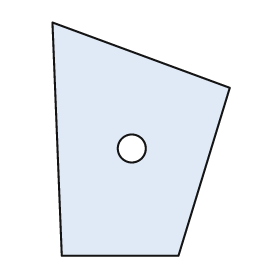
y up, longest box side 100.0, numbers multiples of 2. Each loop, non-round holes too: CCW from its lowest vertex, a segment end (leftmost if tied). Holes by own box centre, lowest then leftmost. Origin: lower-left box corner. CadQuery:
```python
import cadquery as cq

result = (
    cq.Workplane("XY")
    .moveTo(4.0, 0.0)
    .lineTo(54.0, 0.0)
    .lineTo(76.0, 72.0)
    .lineTo(0.0, 100.0)
    .close()
    .moveTo(34.0, 46.0)
    .circle(6.0)
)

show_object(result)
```